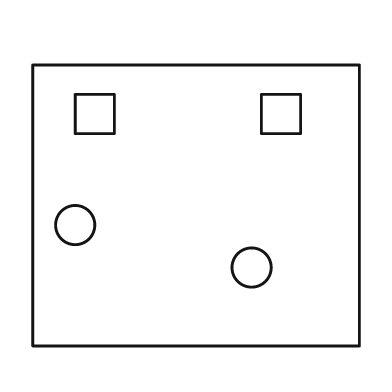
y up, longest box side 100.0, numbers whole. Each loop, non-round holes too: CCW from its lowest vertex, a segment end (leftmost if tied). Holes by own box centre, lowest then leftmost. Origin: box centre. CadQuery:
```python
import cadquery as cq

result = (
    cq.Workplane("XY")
    .moveTo(-50.0, -43.0)
    .lineTo(50.0, -43.0)
    .lineTo(50.0, 43.0)
    .lineTo(-50.0, 43.0)
    .close()
    .moveTo(17.0, -19.0)
    .circle(6.0)
    .moveTo(-37.0, -6.0)
    .circle(6.0)
    .moveTo(-37.0, 22.0)
    .lineTo(-25.0, 22.0)
    .lineTo(-25.0, 34.0)
    .lineTo(-37.0, 34.0)
    .close()
    .moveTo(20.0, 22.0)
    .lineTo(32.0, 22.0)
    .lineTo(32.0, 34.0)
    .lineTo(20.0, 34.0)
    .close()
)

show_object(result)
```